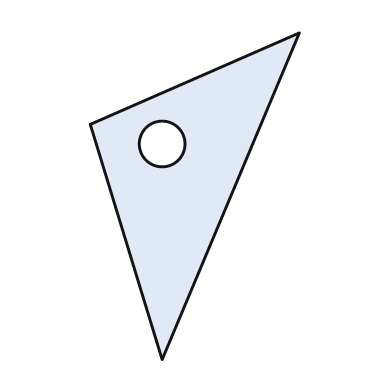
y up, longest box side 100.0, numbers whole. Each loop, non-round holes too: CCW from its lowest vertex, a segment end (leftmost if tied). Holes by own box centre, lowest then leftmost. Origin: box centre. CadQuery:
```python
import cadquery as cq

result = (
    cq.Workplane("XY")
    .moveTo(-10.0, -50.0)
    .lineTo(32.0, 50.0)
    .lineTo(-32.0, 22.0)
    .close()
    .moveTo(-10.0, 16.0)
    .circle(7.0)
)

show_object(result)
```